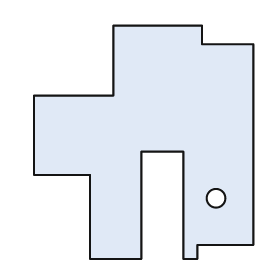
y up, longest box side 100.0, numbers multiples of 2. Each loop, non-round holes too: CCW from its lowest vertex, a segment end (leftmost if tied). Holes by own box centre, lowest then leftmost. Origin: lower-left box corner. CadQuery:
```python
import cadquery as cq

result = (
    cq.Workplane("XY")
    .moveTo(24.0, 0.0)
    .lineTo(46.0, 0.0)
    .lineTo(46.0, 46.0)
    .lineTo(64.0, 46.0)
    .lineTo(64.0, 0.0)
    .lineTo(70.0, 0.0)
    .lineTo(70.0, 6.0)
    .lineTo(94.0, 6.0)
    .lineTo(94.0, 92.0)
    .lineTo(72.0, 92.0)
    .lineTo(72.0, 100.0)
    .lineTo(34.0, 100.0)
    .lineTo(34.0, 70.0)
    .lineTo(0.0, 70.0)
    .lineTo(0.0, 36.0)
    .lineTo(24.0, 36.0)
    .close()
    .moveTo(78.0, 26.0)
    .circle(4.0)
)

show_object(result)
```